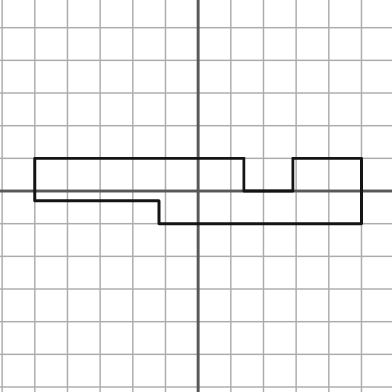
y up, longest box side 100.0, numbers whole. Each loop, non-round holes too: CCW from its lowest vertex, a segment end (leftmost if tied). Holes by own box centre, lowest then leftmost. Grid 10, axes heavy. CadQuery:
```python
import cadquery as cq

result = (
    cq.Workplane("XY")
    .moveTo(-12.0, -10.0)
    .lineTo(50.0, -10.0)
    .lineTo(50.0, 10.0)
    .lineTo(29.0, 10.0)
    .lineTo(29.0, 0.0)
    .lineTo(14.0, 0.0)
    .lineTo(14.0, 10.0)
    .lineTo(-50.0, 10.0)
    .lineTo(-50.0, -3.0)
    .lineTo(-12.0, -3.0)
    .close()
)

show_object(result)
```